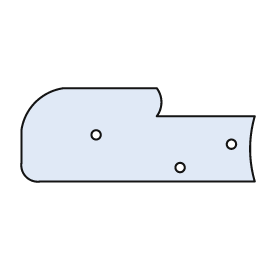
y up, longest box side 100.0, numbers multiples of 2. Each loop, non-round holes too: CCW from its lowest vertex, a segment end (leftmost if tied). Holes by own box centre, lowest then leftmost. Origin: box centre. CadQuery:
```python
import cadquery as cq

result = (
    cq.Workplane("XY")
    .moveTo(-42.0, -20.0)
    .lineTo(50.0, -20.0)
    .threePointArc((48.0, -6.0), (50.0, 8.0))
    .lineTo(8.0, 8.0)
    .threePointArc((10.0, 14.0), (8.0, 20.0))
    .lineTo(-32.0, 20.0)
    .threePointArc((-44.0, 14.0), (-50.0, 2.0))
    .lineTo(-50.0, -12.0)
    .threePointArc((-48.0, -18.0), (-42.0, -20.0))
    .close()
    .moveTo(18.0, -14.0)
    .circle(2.0)
    .moveTo(40.0, -4.0)
    .circle(2.0)
    .moveTo(-18.0, 0.0)
    .circle(2.0)
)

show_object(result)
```